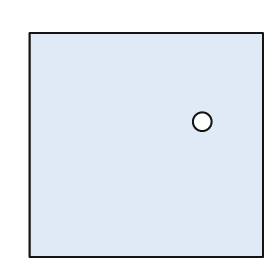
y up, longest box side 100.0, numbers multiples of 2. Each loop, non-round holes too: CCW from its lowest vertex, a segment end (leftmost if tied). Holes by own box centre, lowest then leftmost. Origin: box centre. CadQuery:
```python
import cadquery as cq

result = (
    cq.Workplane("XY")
    .moveTo(-50.0, -48.0)
    .lineTo(50.0, -48.0)
    .lineTo(50.0, 48.0)
    .lineTo(-50.0, 48.0)
    .close()
    .moveTo(24.0, 10.0)
    .circle(4.0)
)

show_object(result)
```